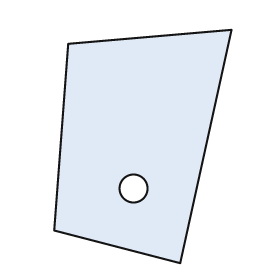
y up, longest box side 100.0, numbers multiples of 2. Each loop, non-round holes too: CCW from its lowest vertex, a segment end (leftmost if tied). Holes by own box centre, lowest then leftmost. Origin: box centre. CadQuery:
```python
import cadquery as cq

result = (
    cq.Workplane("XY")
    .moveTo(16.0, -50.0)
    .lineTo(38.0, 50.0)
    .lineTo(-32.0, 44.0)
    .lineTo(-38.0, -36.0)
    .close()
    .moveTo(-4.0, -18.0)
    .circle(6.0)
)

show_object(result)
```